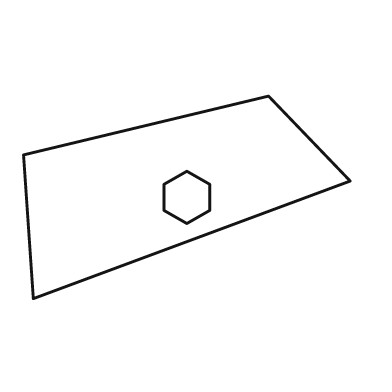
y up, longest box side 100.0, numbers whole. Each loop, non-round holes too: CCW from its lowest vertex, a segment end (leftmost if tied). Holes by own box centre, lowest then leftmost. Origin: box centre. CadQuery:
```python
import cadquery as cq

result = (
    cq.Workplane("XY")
    .moveTo(-47.0, -31.0)
    .lineTo(50.0, 5.0)
    .lineTo(25.0, 31.0)
    .lineTo(-50.0, 13.0)
    .close()
    .moveTo(0.0, -8.0)
    .lineTo(7.0, -4.0)
    .lineTo(7.0, 4.0)
    .lineTo(0.0, 8.0)
    .lineTo(-7.0, 4.0)
    .lineTo(-7.0, -4.0)
    .close()
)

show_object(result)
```